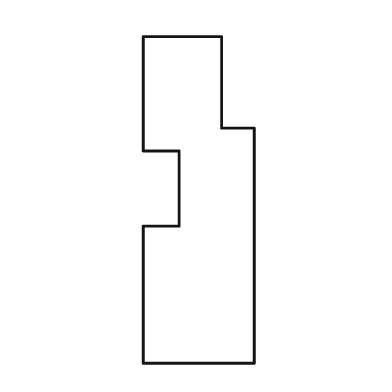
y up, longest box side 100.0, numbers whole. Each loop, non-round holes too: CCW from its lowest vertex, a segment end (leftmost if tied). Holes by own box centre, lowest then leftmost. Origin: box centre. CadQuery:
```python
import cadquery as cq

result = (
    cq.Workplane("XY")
    .moveTo(-17.0, -50.0)
    .lineTo(17.0, -50.0)
    .lineTo(17.0, 22.0)
    .lineTo(7.0, 22.0)
    .lineTo(7.0, 50.0)
    .lineTo(-17.0, 50.0)
    .lineTo(-17.0, 15.0)
    .lineTo(-6.0, 15.0)
    .lineTo(-6.0, -8.0)
    .lineTo(-17.0, -8.0)
    .close()
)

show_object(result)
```